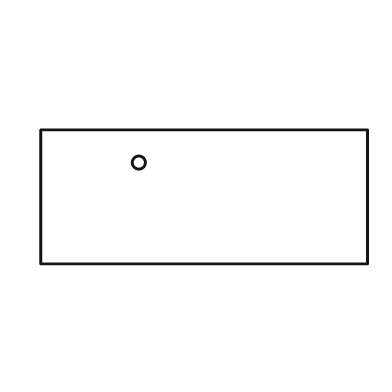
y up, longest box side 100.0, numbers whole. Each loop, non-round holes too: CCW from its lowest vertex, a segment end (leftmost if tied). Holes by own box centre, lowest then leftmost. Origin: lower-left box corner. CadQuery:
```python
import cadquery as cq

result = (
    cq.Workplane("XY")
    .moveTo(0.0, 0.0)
    .lineTo(100.0, 0.0)
    .lineTo(100.0, 41.0)
    .lineTo(0.0, 41.0)
    .close()
    .moveTo(30.0, 31.0)
    .circle(2.0)
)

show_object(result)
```